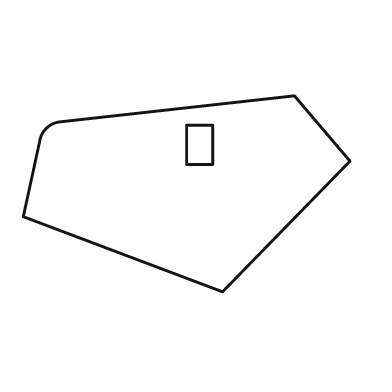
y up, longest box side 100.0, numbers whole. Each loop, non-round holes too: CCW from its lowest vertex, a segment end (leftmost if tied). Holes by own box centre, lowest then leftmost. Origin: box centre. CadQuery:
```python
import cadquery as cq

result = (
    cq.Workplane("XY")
    .moveTo(11.0, -30.0)
    .lineTo(50.0, 10.0)
    .lineTo(33.0, 30.0)
    .lineTo(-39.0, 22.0)
    .threePointArc((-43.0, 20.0), (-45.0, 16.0))
    .lineTo(-50.0, -7.0)
    .close()
    .moveTo(0.0, 9.0)
    .lineTo(8.0, 9.0)
    .lineTo(8.0, 21.0)
    .lineTo(0.0, 21.0)
    .close()
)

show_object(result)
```